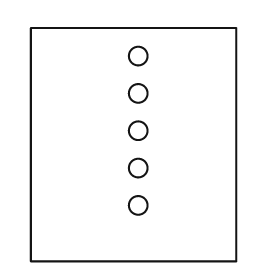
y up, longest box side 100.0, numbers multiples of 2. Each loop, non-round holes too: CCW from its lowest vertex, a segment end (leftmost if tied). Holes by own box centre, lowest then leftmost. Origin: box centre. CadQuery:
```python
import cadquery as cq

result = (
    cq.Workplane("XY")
    .moveTo(-44.0, -50.0)
    .lineTo(44.0, -50.0)
    .lineTo(44.0, 50.0)
    .lineTo(-44.0, 50.0)
    .close()
    .moveTo(2.0, -26.0)
    .circle(4.0)
    .moveTo(2.0, -10.0)
    .circle(4.0)
    .moveTo(2.0, 6.0)
    .circle(4.0)
    .moveTo(2.0, 22.0)
    .circle(4.0)
    .moveTo(2.0, 38.0)
    .circle(4.0)
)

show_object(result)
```